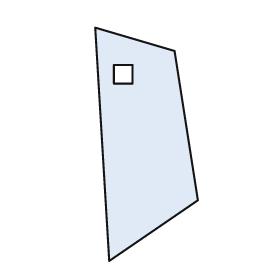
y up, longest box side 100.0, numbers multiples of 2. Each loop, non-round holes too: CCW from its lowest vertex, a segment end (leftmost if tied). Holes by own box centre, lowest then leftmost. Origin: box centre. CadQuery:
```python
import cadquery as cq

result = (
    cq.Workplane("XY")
    .moveTo(-16.0, -50.0)
    .lineTo(22.0, -24.0)
    .lineTo(12.0, 40.0)
    .lineTo(-22.0, 50.0)
    .close()
    .moveTo(-14.0, 26.0)
    .lineTo(-6.0, 26.0)
    .lineTo(-6.0, 34.0)
    .lineTo(-14.0, 34.0)
    .close()
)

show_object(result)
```